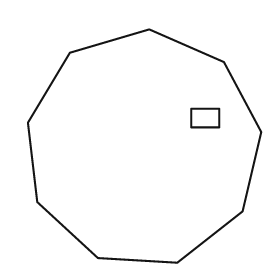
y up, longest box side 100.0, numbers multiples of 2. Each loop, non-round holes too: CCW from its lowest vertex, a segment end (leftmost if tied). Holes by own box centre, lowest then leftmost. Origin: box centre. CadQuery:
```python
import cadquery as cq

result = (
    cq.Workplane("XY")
    .moveTo(14.0, -50.0)
    .lineTo(42.0, -28.0)
    .lineTo(50.0, 6.0)
    .lineTo(34.0, 36.0)
    .lineTo(2.0, 50.0)
    .lineTo(-32.0, 40.0)
    .lineTo(-50.0, 10.0)
    .lineTo(-46.0, -24.0)
    .lineTo(-20.0, -48.0)
    .close()
    .moveTo(20.0, 8.0)
    .lineTo(32.0, 8.0)
    .lineTo(32.0, 16.0)
    .lineTo(20.0, 16.0)
    .close()
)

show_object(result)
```